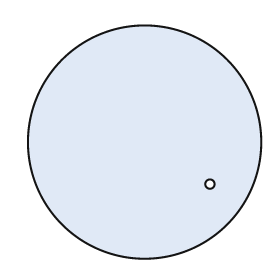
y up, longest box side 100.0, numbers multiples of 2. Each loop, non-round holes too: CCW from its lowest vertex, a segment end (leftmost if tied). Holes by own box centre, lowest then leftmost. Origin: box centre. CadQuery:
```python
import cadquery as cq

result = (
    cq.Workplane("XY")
    .moveTo(0.0, 0.0)
    .circle(50.0)
    .moveTo(28.0, -18.0)
    .circle(2.0)
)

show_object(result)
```